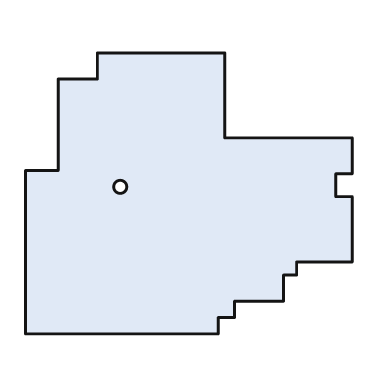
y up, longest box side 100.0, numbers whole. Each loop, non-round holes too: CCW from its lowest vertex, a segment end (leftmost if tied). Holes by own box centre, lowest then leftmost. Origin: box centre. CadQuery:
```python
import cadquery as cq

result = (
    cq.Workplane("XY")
    .moveTo(-50.0, -43.0)
    .lineTo(9.0, -43.0)
    .lineTo(9.0, -38.0)
    .lineTo(14.0, -38.0)
    .lineTo(14.0, -33.0)
    .lineTo(29.0, -33.0)
    .lineTo(29.0, -25.0)
    .lineTo(33.0, -25.0)
    .lineTo(33.0, -21.0)
    .lineTo(50.0, -21.0)
    .lineTo(50.0, -1.0)
    .lineTo(45.0, -1.0)
    .lineTo(45.0, 6.0)
    .lineTo(50.0, 6.0)
    .lineTo(50.0, 17.0)
    .lineTo(11.0, 17.0)
    .lineTo(11.0, 43.0)
    .lineTo(-28.0, 43.0)
    .lineTo(-28.0, 35.0)
    .lineTo(-40.0, 35.0)
    .lineTo(-40.0, 7.0)
    .lineTo(-50.0, 7.0)
    .close()
    .moveTo(-21.0, 2.0)
    .circle(2.0)
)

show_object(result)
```